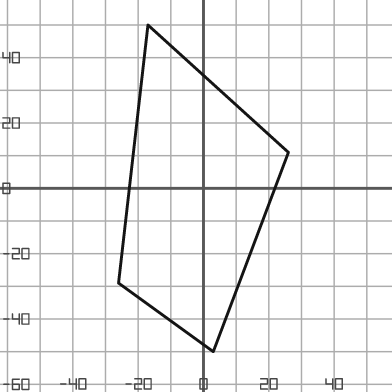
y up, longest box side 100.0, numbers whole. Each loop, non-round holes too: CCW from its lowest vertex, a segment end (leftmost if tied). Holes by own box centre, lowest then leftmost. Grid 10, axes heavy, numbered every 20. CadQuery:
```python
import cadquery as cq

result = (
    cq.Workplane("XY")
    .moveTo(3.0, -50.0)
    .lineTo(26.0, 11.0)
    .lineTo(-17.0, 50.0)
    .lineTo(-26.0, -29.0)
    .close()
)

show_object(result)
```